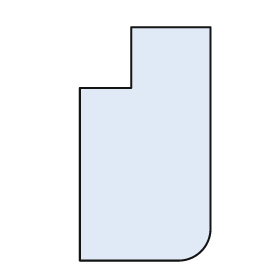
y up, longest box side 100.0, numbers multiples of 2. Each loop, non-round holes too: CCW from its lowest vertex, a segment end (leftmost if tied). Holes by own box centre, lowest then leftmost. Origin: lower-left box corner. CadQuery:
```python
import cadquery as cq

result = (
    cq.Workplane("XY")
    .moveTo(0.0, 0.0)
    .lineTo(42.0, 0.0)
    .threePointArc((52.0, 4.0), (56.0, 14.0))
    .lineTo(56.0, 100.0)
    .lineTo(22.0, 100.0)
    .lineTo(22.0, 74.0)
    .lineTo(0.0, 74.0)
    .close()
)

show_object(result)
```